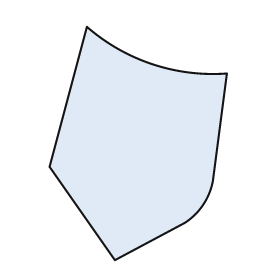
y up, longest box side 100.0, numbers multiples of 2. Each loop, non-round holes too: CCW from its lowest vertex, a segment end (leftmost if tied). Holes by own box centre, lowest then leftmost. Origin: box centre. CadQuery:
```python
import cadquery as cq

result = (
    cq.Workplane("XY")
    .moveTo(-10.0, -50.0)
    .lineTo(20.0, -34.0)
    .threePointArc((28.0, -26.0), (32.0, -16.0))
    .lineTo(38.0, 30.0)
    .threePointArc((6.0, 34.0), (-22.0, 50.0))
    .lineTo(-38.0, -10.0)
    .close()
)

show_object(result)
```